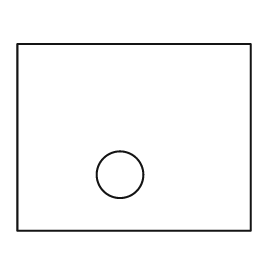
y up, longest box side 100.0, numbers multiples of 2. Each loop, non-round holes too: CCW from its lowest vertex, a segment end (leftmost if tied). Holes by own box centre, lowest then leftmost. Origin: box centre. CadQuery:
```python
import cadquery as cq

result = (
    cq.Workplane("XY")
    .moveTo(-50.0, -40.0)
    .lineTo(50.0, -40.0)
    .lineTo(50.0, 40.0)
    .lineTo(-50.0, 40.0)
    .close()
    .moveTo(-6.0, -16.0)
    .circle(10.0)
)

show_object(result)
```